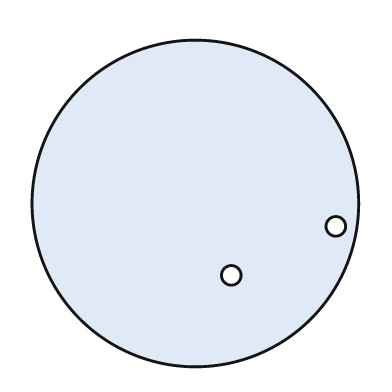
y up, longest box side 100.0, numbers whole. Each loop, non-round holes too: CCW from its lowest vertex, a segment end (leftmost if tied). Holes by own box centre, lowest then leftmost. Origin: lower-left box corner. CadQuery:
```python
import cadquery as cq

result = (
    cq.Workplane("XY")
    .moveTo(50.0, 50.0)
    .circle(50.0)
    .moveTo(61.0, 28.0)
    .circle(3.0)
    .moveTo(93.0, 43.0)
    .circle(3.0)
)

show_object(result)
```